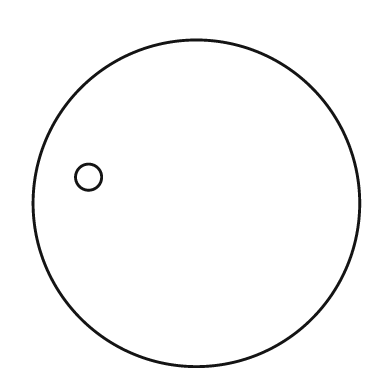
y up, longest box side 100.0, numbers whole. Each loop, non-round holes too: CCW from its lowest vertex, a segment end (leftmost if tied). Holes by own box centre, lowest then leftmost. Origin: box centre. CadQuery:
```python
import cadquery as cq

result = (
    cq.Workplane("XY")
    .moveTo(0.0, 0.0)
    .circle(50.0)
    .moveTo(-33.0, 8.0)
    .circle(4.0)
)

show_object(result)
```